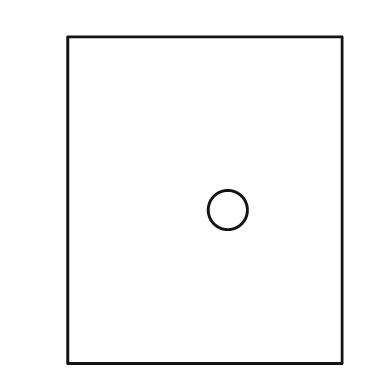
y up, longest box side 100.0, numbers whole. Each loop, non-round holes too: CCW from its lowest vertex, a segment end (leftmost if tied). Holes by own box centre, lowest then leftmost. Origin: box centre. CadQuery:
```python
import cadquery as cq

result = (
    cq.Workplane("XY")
    .moveTo(-42.0, -50.0)
    .lineTo(42.0, -50.0)
    .lineTo(42.0, 50.0)
    .lineTo(-42.0, 50.0)
    .close()
    .moveTo(7.0, -3.0)
    .circle(6.0)
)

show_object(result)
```